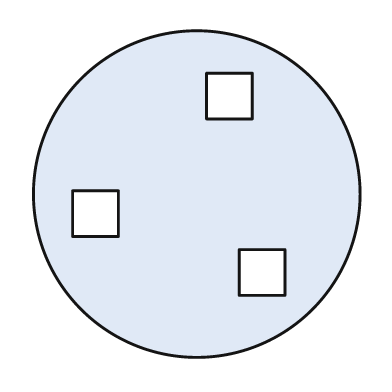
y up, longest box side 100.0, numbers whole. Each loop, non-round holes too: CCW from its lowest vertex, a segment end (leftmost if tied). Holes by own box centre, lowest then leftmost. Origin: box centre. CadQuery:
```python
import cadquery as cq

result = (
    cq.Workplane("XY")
    .moveTo(0.0, 0.0)
    .circle(50.0)
    .moveTo(13.0, -31.0)
    .lineTo(27.0, -31.0)
    .lineTo(27.0, -17.0)
    .lineTo(13.0, -17.0)
    .close()
    .moveTo(-38.0, -13.0)
    .lineTo(-24.0, -13.0)
    .lineTo(-24.0, 1.0)
    .lineTo(-38.0, 1.0)
    .close()
    .moveTo(3.0, 23.0)
    .lineTo(17.0, 23.0)
    .lineTo(17.0, 37.0)
    .lineTo(3.0, 37.0)
    .close()
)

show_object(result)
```